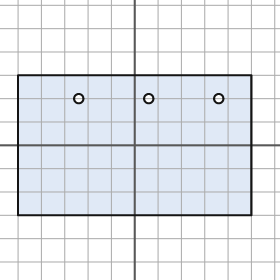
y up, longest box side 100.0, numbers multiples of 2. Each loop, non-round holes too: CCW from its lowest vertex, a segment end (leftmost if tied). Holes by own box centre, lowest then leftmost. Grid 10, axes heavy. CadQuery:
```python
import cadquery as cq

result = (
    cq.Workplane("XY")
    .moveTo(-50.0, -30.0)
    .lineTo(50.0, -30.0)
    .lineTo(50.0, 30.0)
    .lineTo(-50.0, 30.0)
    .close()
    .moveTo(-24.0, 20.0)
    .circle(2.0)
    .moveTo(6.0, 20.0)
    .circle(2.0)
    .moveTo(36.0, 20.0)
    .circle(2.0)
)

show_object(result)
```